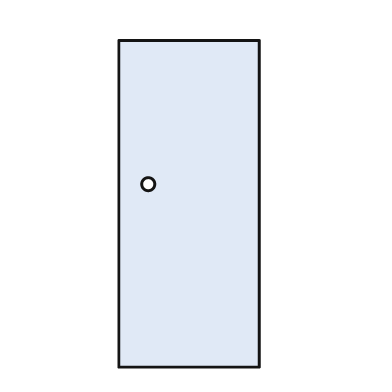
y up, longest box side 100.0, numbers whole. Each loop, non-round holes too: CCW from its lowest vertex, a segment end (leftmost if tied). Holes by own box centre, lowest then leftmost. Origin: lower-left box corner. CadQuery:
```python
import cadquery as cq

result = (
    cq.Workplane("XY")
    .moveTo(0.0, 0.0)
    .lineTo(43.0, 0.0)
    .lineTo(43.0, 100.0)
    .lineTo(0.0, 100.0)
    .close()
    .moveTo(9.0, 56.0)
    .circle(2.0)
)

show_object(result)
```